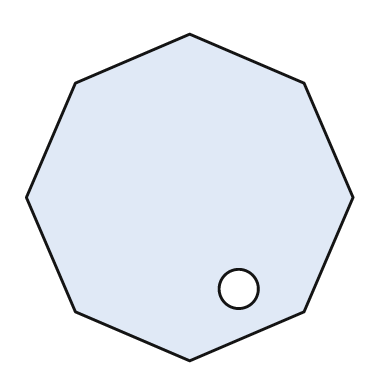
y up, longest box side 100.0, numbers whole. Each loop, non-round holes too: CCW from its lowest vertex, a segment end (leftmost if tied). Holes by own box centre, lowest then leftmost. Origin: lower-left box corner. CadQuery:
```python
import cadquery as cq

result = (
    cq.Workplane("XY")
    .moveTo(50.0, 0.0)
    .lineTo(85.0, 15.0)
    .lineTo(100.0, 50.0)
    .lineTo(85.0, 85.0)
    .lineTo(50.0, 100.0)
    .lineTo(15.0, 85.0)
    .lineTo(0.0, 50.0)
    .lineTo(15.0, 15.0)
    .close()
    .moveTo(65.0, 22.0)
    .circle(6.0)
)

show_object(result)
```